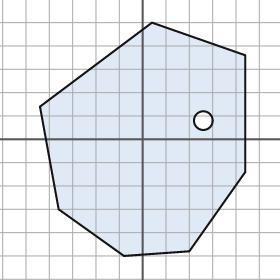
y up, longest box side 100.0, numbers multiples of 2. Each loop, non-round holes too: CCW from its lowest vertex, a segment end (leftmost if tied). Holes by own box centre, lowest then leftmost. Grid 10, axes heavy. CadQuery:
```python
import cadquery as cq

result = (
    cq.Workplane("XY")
    .moveTo(-8.0, -50.0)
    .lineTo(20.0, -48.0)
    .lineTo(44.0, -14.0)
    .lineTo(44.0, 36.0)
    .lineTo(4.0, 50.0)
    .lineTo(-44.0, 14.0)
    .lineTo(-36.0, -30.0)
    .close()
    .moveTo(26.0, 8.0)
    .circle(4.0)
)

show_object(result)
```